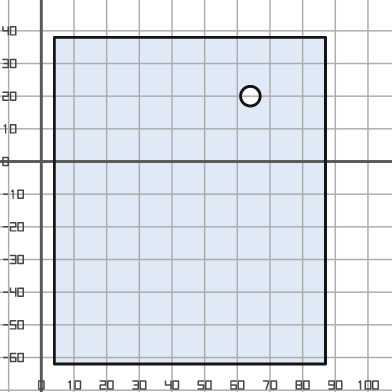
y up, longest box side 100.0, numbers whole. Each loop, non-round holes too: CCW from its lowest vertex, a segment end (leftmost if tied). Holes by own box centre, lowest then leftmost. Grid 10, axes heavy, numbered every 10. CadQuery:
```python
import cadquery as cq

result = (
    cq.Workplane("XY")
    .moveTo(4.0, -62.0)
    .lineTo(87.0, -62.0)
    .lineTo(87.0, 38.0)
    .lineTo(4.0, 38.0)
    .close()
    .moveTo(64.0, 20.0)
    .circle(3.0)
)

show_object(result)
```